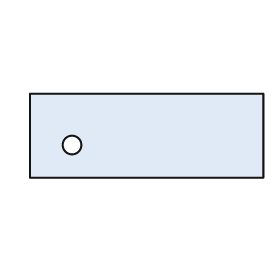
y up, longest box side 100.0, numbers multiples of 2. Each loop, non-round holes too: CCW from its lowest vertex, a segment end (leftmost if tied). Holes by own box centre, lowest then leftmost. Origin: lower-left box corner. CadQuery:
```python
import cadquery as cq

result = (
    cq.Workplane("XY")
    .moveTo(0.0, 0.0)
    .lineTo(100.0, 0.0)
    .lineTo(100.0, 36.0)
    .lineTo(0.0, 36.0)
    .close()
    .moveTo(18.0, 14.0)
    .circle(4.0)
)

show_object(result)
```